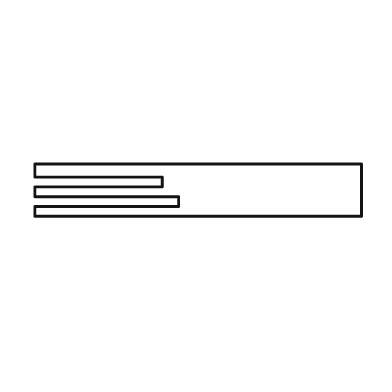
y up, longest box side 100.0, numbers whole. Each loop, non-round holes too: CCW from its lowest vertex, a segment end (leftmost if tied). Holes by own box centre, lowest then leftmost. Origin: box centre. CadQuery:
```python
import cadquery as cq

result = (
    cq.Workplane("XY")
    .moveTo(-50.0, -8.0)
    .lineTo(50.0, -8.0)
    .lineTo(50.0, 8.0)
    .lineTo(-50.0, 8.0)
    .lineTo(-50.0, 4.0)
    .lineTo(-11.0, 4.0)
    .lineTo(-11.0, 1.0)
    .lineTo(-50.0, 1.0)
    .lineTo(-50.0, -2.0)
    .lineTo(-6.0, -2.0)
    .lineTo(-6.0, -5.0)
    .lineTo(-50.0, -5.0)
    .close()
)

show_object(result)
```